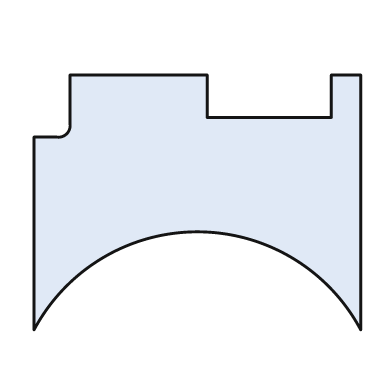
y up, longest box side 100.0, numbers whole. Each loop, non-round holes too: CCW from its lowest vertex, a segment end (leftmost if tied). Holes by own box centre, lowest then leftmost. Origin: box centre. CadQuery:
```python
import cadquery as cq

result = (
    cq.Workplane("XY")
    .moveTo(-50.0, -39.0)
    .threePointArc((0.0, -9.0), (50.0, -39.0))
    .lineTo(50.0, 39.0)
    .lineTo(41.0, 39.0)
    .lineTo(41.0, 26.0)
    .lineTo(3.0, 26.0)
    .lineTo(3.0, 39.0)
    .lineTo(-39.0, 39.0)
    .lineTo(-39.0, 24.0)
    .threePointArc((-40.0, 21.0), (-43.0, 20.0))
    .lineTo(-50.0, 20.0)
    .close()
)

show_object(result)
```